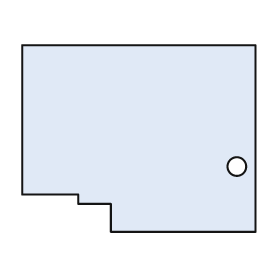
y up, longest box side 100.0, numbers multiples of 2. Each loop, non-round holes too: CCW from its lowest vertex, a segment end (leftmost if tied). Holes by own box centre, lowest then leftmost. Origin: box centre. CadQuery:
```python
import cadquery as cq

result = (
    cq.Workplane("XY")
    .moveTo(-12.0, -40.0)
    .lineTo(50.0, -40.0)
    .lineTo(50.0, 40.0)
    .lineTo(-50.0, 40.0)
    .lineTo(-50.0, -24.0)
    .lineTo(-26.0, -24.0)
    .lineTo(-26.0, -28.0)
    .lineTo(-12.0, -28.0)
    .close()
    .moveTo(42.0, -12.0)
    .circle(4.0)
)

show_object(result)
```